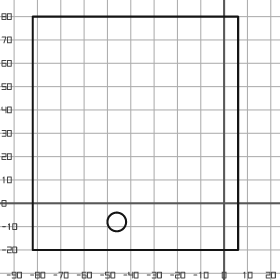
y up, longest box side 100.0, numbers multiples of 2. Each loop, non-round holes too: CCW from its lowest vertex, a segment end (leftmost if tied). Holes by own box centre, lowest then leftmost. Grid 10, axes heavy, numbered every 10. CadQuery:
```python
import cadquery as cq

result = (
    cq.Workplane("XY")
    .moveTo(-82.0, -20.0)
    .lineTo(6.0, -20.0)
    .lineTo(6.0, 80.0)
    .lineTo(-82.0, 80.0)
    .close()
    .moveTo(-46.0, -8.0)
    .circle(4.0)
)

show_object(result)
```